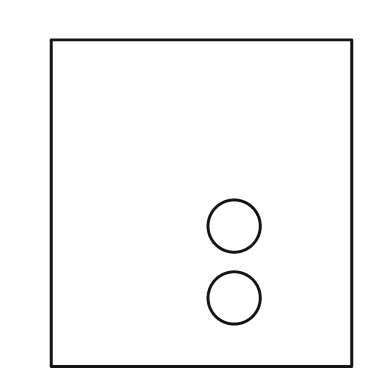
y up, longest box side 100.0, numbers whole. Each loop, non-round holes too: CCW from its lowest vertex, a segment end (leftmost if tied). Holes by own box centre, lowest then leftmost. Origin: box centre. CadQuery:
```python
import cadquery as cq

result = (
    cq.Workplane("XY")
    .moveTo(-46.0, -50.0)
    .lineTo(46.0, -50.0)
    .lineTo(46.0, 50.0)
    .lineTo(-46.0, 50.0)
    .close()
    .moveTo(10.0, -29.0)
    .circle(8.0)
    .moveTo(10.0, -7.0)
    .circle(8.0)
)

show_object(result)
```